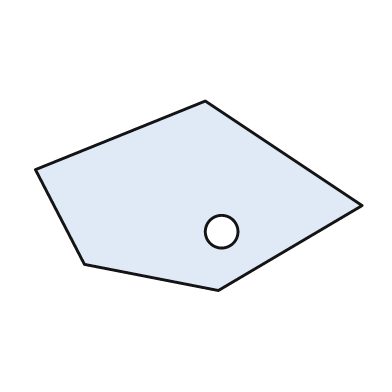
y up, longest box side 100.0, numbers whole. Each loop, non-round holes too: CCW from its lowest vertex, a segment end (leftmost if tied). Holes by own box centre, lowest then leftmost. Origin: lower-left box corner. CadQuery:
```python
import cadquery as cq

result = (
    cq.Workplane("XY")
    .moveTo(56.0, 0.0)
    .lineTo(100.0, 26.0)
    .lineTo(52.0, 58.0)
    .lineTo(0.0, 37.0)
    .lineTo(15.0, 8.0)
    .close()
    .moveTo(57.0, 18.0)
    .circle(5.0)
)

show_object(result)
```